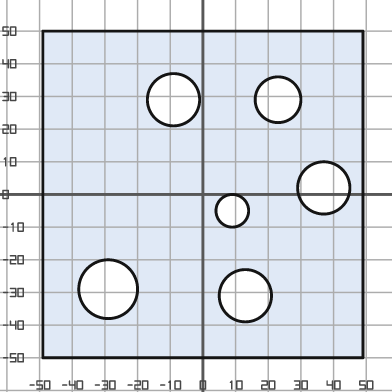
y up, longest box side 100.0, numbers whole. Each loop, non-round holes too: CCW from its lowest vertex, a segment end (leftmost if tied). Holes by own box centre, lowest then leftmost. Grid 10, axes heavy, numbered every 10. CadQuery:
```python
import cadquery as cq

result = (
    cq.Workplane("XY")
    .moveTo(-49.0, -50.0)
    .lineTo(49.0, -50.0)
    .lineTo(49.0, 50.0)
    .lineTo(-49.0, 50.0)
    .close()
    .moveTo(13.0, -31.0)
    .circle(8.0)
    .moveTo(-29.0, -29.0)
    .circle(9.0)
    .moveTo(9.0, -5.0)
    .circle(5.0)
    .moveTo(37.0, 2.0)
    .circle(8.0)
    .moveTo(-9.0, 29.0)
    .circle(8.0)
    .moveTo(23.0, 29.0)
    .circle(7.0)
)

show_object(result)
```